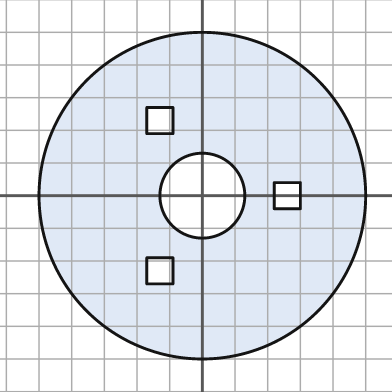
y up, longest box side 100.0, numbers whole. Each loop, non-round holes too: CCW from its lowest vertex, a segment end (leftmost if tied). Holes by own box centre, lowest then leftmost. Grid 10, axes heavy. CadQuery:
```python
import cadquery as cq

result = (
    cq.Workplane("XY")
    .moveTo(0.0, 0.0)
    .circle(50.0)
    .moveTo(-17.0, -27.0)
    .lineTo(-9.0, -27.0)
    .lineTo(-9.0, -19.0)
    .lineTo(-17.0, -19.0)
    .close()
    .moveTo(0.0, 0.0)
    .circle(13.0)
    .moveTo(22.0, -4.0)
    .lineTo(30.0, -4.0)
    .lineTo(30.0, 4.0)
    .lineTo(22.0, 4.0)
    .close()
    .moveTo(-17.0, 19.0)
    .lineTo(-9.0, 19.0)
    .lineTo(-9.0, 27.0)
    .lineTo(-17.0, 27.0)
    .close()
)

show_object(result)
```